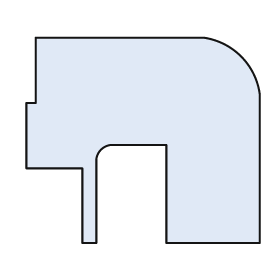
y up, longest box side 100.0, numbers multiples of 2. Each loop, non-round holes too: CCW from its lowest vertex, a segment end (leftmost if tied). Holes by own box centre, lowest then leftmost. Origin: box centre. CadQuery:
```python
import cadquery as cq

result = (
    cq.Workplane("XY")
    .moveTo(-26.0, -44.0)
    .lineTo(-20.0, -44.0)
    .lineTo(-20.0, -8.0)
    .threePointArc((-18.0, -4.0), (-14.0, -2.0))
    .lineTo(10.0, -2.0)
    .lineTo(10.0, -44.0)
    .lineTo(50.0, -44.0)
    .lineTo(50.0, 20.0)
    .threePointArc((42.0, 36.0), (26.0, 44.0))
    .lineTo(-46.0, 44.0)
    .lineTo(-46.0, 16.0)
    .lineTo(-50.0, 16.0)
    .lineTo(-50.0, -12.0)
    .lineTo(-26.0, -12.0)
    .close()
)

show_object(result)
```